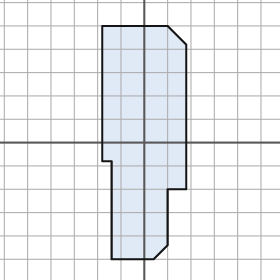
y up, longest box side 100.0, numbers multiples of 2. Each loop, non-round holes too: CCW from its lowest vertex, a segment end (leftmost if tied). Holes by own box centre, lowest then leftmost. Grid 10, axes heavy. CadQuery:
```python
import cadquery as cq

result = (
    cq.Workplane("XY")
    .moveTo(-14.0, -50.0)
    .lineTo(4.0, -50.0)
    .lineTo(10.0, -44.0)
    .lineTo(10.0, -20.0)
    .lineTo(18.0, -20.0)
    .lineTo(18.0, 42.0)
    .lineTo(10.0, 50.0)
    .lineTo(-18.0, 50.0)
    .lineTo(-18.0, -8.0)
    .lineTo(-14.0, -8.0)
    .close()
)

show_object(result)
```